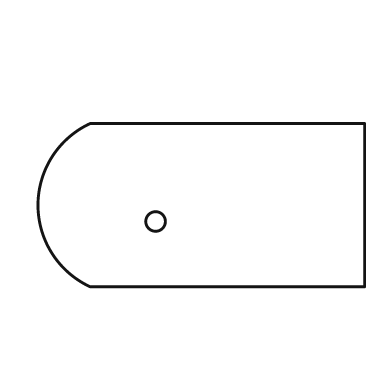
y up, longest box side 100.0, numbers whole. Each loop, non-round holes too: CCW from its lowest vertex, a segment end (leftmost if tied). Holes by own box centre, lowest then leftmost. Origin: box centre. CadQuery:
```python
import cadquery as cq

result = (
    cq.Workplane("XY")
    .moveTo(-34.0, -25.0)
    .lineTo(50.0, -25.0)
    .lineTo(50.0, 25.0)
    .lineTo(-34.0, 25.0)
    .threePointArc((-50.0, 0.0), (-34.0, -25.0))
    .close()
    .moveTo(-14.0, -5.0)
    .circle(3.0)
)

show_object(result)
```